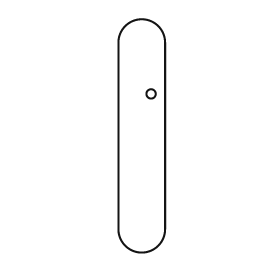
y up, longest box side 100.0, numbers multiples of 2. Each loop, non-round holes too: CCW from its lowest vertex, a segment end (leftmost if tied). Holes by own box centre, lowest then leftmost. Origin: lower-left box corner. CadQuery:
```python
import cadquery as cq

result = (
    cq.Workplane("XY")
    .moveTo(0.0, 10.0)
    .threePointArc((10.0, 0.0), (20.0, 10.0))
    .lineTo(20.0, 90.0)
    .threePointArc((10.0, 100.0), (0.0, 90.0))
    .close()
    .moveTo(14.0, 68.0)
    .circle(2.0)
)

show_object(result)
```